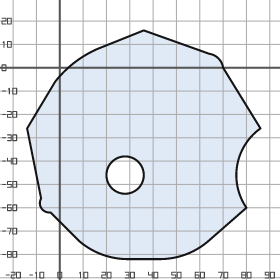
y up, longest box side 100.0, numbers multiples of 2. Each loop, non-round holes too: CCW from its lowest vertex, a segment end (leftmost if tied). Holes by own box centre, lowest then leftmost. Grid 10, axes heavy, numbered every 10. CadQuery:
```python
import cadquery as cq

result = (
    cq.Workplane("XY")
    .moveTo(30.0, -82.0)
    .lineTo(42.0, -82.0)
    .threePointArc((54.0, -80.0), (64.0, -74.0))
    .lineTo(80.0, -60.0)
    .threePointArc((76.0, -42.0), (86.0, -26.0))
    .lineTo(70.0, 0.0)
    .threePointArc((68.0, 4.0), (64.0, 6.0))
    .lineTo(36.0, 16.0)
    .lineTo(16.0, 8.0)
    .threePointArc((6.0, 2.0), (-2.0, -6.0))
    .lineTo(-14.0, -26.0)
    .lineTo(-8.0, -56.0)
    .threePointArc((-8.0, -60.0), (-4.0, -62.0))
    .lineTo(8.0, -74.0)
    .threePointArc((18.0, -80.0), (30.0, -82.0))
    .close()
    .moveTo(28.0, -46.0)
    .circle(8.0)
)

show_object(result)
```